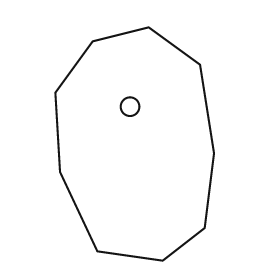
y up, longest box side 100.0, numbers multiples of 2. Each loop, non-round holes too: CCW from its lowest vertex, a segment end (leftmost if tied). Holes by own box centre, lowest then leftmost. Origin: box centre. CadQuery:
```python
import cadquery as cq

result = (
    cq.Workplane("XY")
    .moveTo(12.0, -50.0)
    .lineTo(30.0, -36.0)
    .lineTo(34.0, -4.0)
    .lineTo(28.0, 34.0)
    .lineTo(6.0, 50.0)
    .lineTo(-18.0, 44.0)
    .lineTo(-34.0, 22.0)
    .lineTo(-32.0, -12.0)
    .lineTo(-16.0, -46.0)
    .close()
    .moveTo(-2.0, 16.0)
    .circle(4.0)
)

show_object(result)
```